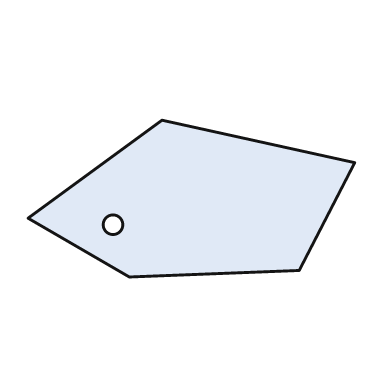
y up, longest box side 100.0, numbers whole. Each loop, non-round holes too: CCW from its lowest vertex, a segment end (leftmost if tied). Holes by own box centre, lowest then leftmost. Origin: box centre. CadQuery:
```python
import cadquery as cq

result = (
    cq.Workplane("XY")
    .moveTo(-19.0, -24.0)
    .lineTo(33.0, -22.0)
    .lineTo(50.0, 11.0)
    .lineTo(-9.0, 24.0)
    .lineTo(-50.0, -6.0)
    .close()
    .moveTo(-24.0, -8.0)
    .circle(3.0)
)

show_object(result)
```